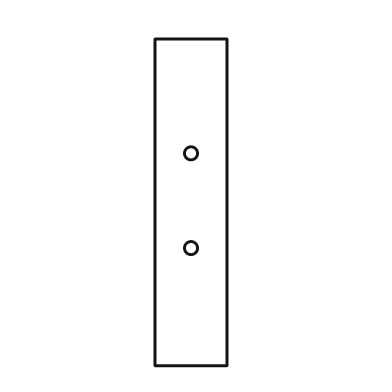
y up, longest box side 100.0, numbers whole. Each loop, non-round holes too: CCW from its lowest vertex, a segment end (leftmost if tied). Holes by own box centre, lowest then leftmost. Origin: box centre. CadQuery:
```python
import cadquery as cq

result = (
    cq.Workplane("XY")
    .moveTo(-11.0, -50.0)
    .lineTo(11.0, -50.0)
    .lineTo(11.0, 50.0)
    .lineTo(-11.0, 50.0)
    .close()
    .moveTo(0.0, -14.0)
    .circle(2.0)
    .moveTo(0.0, 15.0)
    .circle(2.0)
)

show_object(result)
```